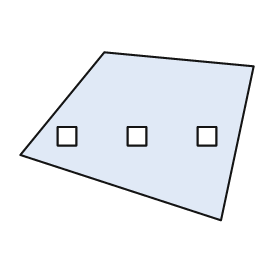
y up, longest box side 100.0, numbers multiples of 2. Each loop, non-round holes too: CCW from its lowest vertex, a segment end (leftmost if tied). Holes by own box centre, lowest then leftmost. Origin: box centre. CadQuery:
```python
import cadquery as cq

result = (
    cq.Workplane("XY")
    .moveTo(36.0, -36.0)
    .lineTo(50.0, 30.0)
    .lineTo(-14.0, 36.0)
    .lineTo(-50.0, -8.0)
    .close()
    .moveTo(-34.0, -4.0)
    .lineTo(-26.0, -4.0)
    .lineTo(-26.0, 4.0)
    .lineTo(-34.0, 4.0)
    .close()
    .moveTo(-4.0, -4.0)
    .lineTo(4.0, -4.0)
    .lineTo(4.0, 4.0)
    .lineTo(-4.0, 4.0)
    .close()
    .moveTo(26.0, -4.0)
    .lineTo(34.0, -4.0)
    .lineTo(34.0, 4.0)
    .lineTo(26.0, 4.0)
    .close()
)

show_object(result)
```